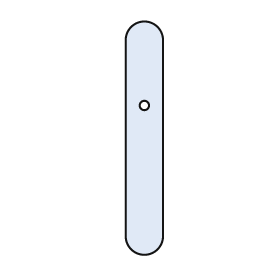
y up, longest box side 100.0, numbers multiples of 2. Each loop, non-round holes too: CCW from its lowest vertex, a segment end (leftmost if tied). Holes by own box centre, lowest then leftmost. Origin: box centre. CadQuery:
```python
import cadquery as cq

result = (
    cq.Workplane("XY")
    .moveTo(-8.0, -42.0)
    .threePointArc((0.0, -50.0), (8.0, -42.0))
    .lineTo(8.0, 42.0)
    .threePointArc((0.0, 50.0), (-8.0, 42.0))
    .close()
    .moveTo(0.0, 14.0)
    .circle(2.0)
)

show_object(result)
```